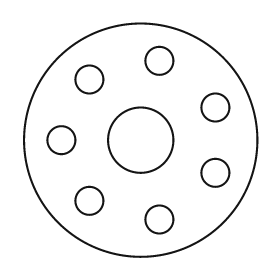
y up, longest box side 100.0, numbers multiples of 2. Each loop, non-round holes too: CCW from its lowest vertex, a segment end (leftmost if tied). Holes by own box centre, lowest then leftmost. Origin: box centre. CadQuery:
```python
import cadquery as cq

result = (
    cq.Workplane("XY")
    .moveTo(0.0, 0.0)
    .circle(50.0)
    .moveTo(8.0, -34.0)
    .circle(6.0)
    .moveTo(-22.0, -26.0)
    .circle(6.0)
    .moveTo(32.0, -14.0)
    .circle(6.0)
    .moveTo(-34.0, 0.0)
    .circle(6.0)
    .moveTo(0.0, 0.0)
    .circle(14.0)
    .moveTo(32.0, 14.0)
    .circle(6.0)
    .moveTo(-22.0, 26.0)
    .circle(6.0)
    .moveTo(8.0, 34.0)
    .circle(6.0)
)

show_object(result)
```